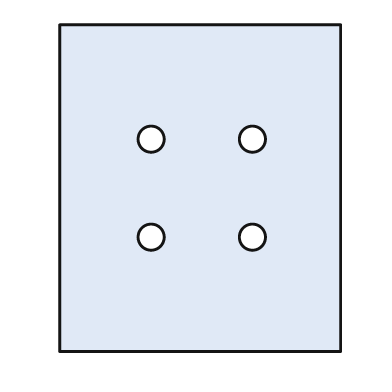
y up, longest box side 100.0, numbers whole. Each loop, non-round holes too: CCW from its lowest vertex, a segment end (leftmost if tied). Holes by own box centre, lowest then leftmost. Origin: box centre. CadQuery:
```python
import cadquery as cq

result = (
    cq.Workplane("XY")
    .moveTo(-43.0, -50.0)
    .lineTo(43.0, -50.0)
    .lineTo(43.0, 50.0)
    .lineTo(-43.0, 50.0)
    .close()
    .moveTo(-15.0, -15.0)
    .circle(4.0)
    .moveTo(16.0, -15.0)
    .circle(4.0)
    .moveTo(-15.0, 15.0)
    .circle(4.0)
    .moveTo(16.0, 15.0)
    .circle(4.0)
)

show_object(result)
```